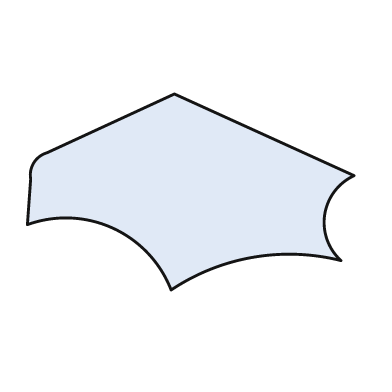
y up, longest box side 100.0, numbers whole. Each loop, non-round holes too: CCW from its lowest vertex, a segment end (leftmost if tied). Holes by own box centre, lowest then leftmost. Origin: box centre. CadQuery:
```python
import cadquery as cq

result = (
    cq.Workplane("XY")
    .moveTo(-6.0, -30.0)
    .threePointArc((19.0, -20.0), (46.0, -21.0))
    .threePointArc((41.0, -7.0), (50.0, 5.0))
    .lineTo(-5.0, 30.0)
    .lineTo(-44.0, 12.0)
    .threePointArc((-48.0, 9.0), (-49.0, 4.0))
    .lineTo(-50.0, -10.0)
    .threePointArc((-24.0, -11.0), (-6.0, -30.0))
    .close()
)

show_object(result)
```